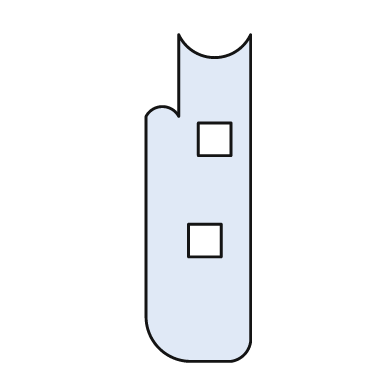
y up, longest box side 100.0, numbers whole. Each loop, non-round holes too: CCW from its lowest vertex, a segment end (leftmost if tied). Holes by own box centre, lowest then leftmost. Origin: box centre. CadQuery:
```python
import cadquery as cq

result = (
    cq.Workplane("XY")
    .moveTo(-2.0, -50.0)
    .lineTo(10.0, -50.0)
    .threePointArc((14.0, -48.0), (16.0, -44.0))
    .lineTo(16.0, 50.0)
    .threePointArc((5.0, 43.0), (-6.0, 50.0))
    .lineTo(-6.0, 25.0)
    .threePointArc((-11.0, 28.0), (-16.0, 25.0))
    .lineTo(-16.0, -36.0)
    .threePointArc((-12.0, -46.0), (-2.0, -50.0))
    .close()
    .moveTo(-3.0, -18.0)
    .lineTo(7.0, -18.0)
    .lineTo(7.0, -8.0)
    .lineTo(-3.0, -8.0)
    .close()
    .moveTo(0.0, 13.0)
    .lineTo(10.0, 13.0)
    .lineTo(10.0, 23.0)
    .lineTo(0.0, 23.0)
    .close()
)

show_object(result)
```